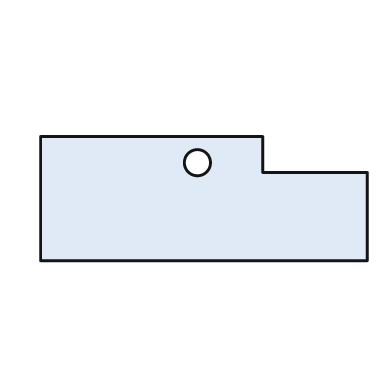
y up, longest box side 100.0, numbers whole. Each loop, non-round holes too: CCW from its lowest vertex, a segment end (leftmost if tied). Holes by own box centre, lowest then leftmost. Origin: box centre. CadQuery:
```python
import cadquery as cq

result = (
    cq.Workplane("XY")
    .moveTo(-50.0, -19.0)
    .lineTo(50.0, -19.0)
    .lineTo(50.0, 8.0)
    .lineTo(18.0, 8.0)
    .lineTo(18.0, 19.0)
    .lineTo(-50.0, 19.0)
    .close()
    .moveTo(-2.0, 11.0)
    .circle(4.0)
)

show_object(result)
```